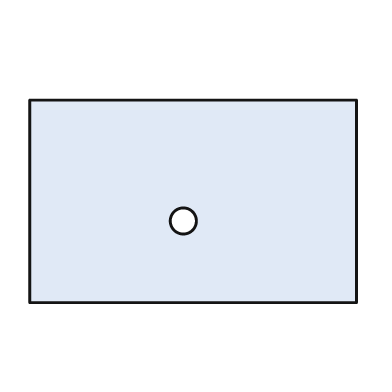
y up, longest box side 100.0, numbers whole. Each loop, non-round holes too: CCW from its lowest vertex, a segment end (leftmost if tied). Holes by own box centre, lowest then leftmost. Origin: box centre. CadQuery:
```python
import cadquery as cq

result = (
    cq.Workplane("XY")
    .moveTo(-50.0, -31.0)
    .lineTo(50.0, -31.0)
    .lineTo(50.0, 31.0)
    .lineTo(-50.0, 31.0)
    .close()
    .moveTo(-3.0, -6.0)
    .circle(4.0)
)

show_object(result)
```